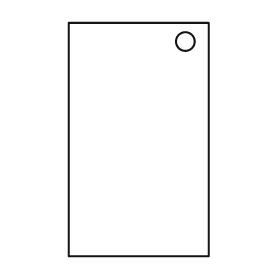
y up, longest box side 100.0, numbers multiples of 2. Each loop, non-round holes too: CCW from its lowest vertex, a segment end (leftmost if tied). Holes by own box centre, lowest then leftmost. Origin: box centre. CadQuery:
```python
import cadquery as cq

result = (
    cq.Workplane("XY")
    .moveTo(-30.0, -50.0)
    .lineTo(30.0, -50.0)
    .lineTo(30.0, 50.0)
    .lineTo(-30.0, 50.0)
    .close()
    .moveTo(20.0, 42.0)
    .circle(4.0)
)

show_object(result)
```